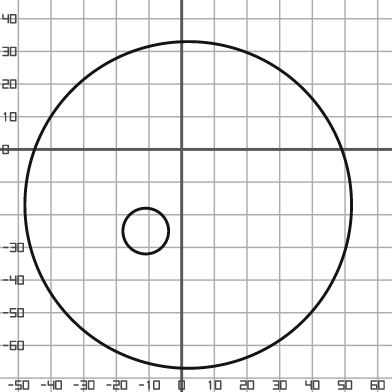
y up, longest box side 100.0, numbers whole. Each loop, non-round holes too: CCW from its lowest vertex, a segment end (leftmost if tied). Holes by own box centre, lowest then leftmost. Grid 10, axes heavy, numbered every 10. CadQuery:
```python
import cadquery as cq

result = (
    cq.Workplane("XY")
    .moveTo(2.0, -17.0)
    .circle(50.0)
    .moveTo(-11.0, -25.0)
    .circle(7.0)
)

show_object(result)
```